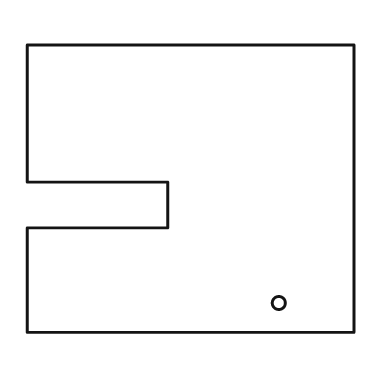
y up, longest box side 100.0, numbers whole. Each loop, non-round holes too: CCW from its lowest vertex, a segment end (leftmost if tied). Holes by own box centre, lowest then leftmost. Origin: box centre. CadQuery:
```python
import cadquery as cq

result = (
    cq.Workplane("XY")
    .moveTo(-50.0, -44.0)
    .lineTo(50.0, -44.0)
    .lineTo(50.0, 44.0)
    .lineTo(-50.0, 44.0)
    .lineTo(-50.0, 2.0)
    .lineTo(-7.0, 2.0)
    .lineTo(-7.0, -12.0)
    .lineTo(-50.0, -12.0)
    .close()
    .moveTo(27.0, -35.0)
    .circle(2.0)
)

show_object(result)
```